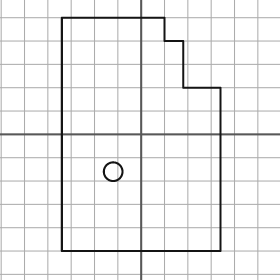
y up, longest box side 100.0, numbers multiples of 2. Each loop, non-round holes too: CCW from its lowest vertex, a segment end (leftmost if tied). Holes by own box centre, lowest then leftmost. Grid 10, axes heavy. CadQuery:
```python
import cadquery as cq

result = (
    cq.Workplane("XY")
    .moveTo(-34.0, -50.0)
    .lineTo(34.0, -50.0)
    .lineTo(34.0, 20.0)
    .lineTo(18.0, 20.0)
    .lineTo(18.0, 40.0)
    .lineTo(10.0, 40.0)
    .lineTo(10.0, 50.0)
    .lineTo(-34.0, 50.0)
    .close()
    .moveTo(-12.0, -16.0)
    .circle(4.0)
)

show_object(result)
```